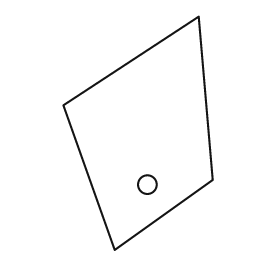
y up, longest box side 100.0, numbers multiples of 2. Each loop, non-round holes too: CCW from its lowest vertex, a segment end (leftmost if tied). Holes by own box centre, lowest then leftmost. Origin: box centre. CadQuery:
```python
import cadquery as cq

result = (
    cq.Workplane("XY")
    .moveTo(-10.0, -50.0)
    .lineTo(32.0, -20.0)
    .lineTo(26.0, 50.0)
    .lineTo(-32.0, 12.0)
    .close()
    .moveTo(4.0, -22.0)
    .circle(4.0)
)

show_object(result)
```